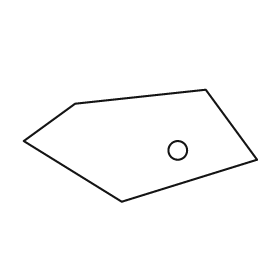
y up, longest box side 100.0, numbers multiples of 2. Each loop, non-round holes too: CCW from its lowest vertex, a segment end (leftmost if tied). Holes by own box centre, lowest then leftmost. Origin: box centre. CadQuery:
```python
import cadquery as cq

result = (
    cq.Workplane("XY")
    .moveTo(-8.0, -24.0)
    .lineTo(50.0, -6.0)
    .lineTo(28.0, 24.0)
    .lineTo(-28.0, 18.0)
    .lineTo(-50.0, 2.0)
    .close()
    .moveTo(16.0, -2.0)
    .circle(4.0)
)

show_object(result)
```